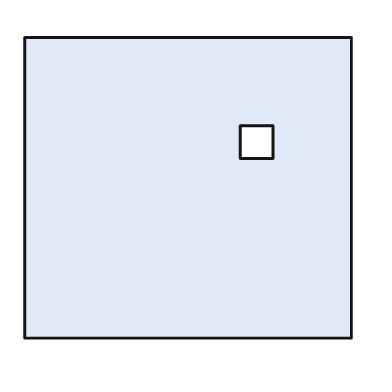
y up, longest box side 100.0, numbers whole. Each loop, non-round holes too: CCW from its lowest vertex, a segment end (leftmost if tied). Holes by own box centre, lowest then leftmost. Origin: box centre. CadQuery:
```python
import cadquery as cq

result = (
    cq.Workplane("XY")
    .moveTo(-50.0, -46.0)
    .lineTo(50.0, -46.0)
    .lineTo(50.0, 46.0)
    .lineTo(-50.0, 46.0)
    .close()
    .moveTo(16.0, 9.0)
    .lineTo(26.0, 9.0)
    .lineTo(26.0, 19.0)
    .lineTo(16.0, 19.0)
    .close()
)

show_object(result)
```